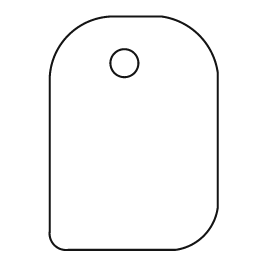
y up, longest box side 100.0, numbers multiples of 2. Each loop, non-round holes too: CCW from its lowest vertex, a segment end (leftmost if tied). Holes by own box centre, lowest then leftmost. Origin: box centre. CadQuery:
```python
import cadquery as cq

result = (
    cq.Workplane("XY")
    .moveTo(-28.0, -50.0)
    .lineTo(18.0, -50.0)
    .threePointArc((30.0, -44.0), (36.0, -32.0))
    .lineTo(36.0, 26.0)
    .threePointArc((28.0, 42.0), (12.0, 50.0))
    .lineTo(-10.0, 50.0)
    .threePointArc((-28.0, 42.0), (-36.0, 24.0))
    .lineTo(-36.0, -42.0)
    .threePointArc((-34.0, -48.0), (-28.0, -50.0))
    .close()
    .moveTo(-4.0, 30.0)
    .circle(6.0)
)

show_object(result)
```